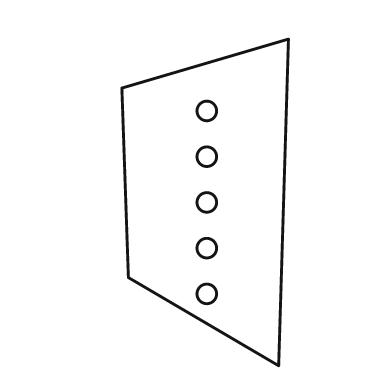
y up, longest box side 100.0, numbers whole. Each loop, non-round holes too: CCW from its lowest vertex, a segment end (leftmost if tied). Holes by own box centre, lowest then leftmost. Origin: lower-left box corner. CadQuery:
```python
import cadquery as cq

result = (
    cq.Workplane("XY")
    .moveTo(48.0, 0.0)
    .lineTo(51.0, 100.0)
    .lineTo(0.0, 85.0)
    .lineTo(2.0, 27.0)
    .close()
    .moveTo(26.0, 22.0)
    .circle(3.0)
    .moveTo(26.0, 36.0)
    .circle(3.0)
    .moveTo(26.0, 50.0)
    .circle(3.0)
    .moveTo(26.0, 64.0)
    .circle(3.0)
    .moveTo(26.0, 78.0)
    .circle(3.0)
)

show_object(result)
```